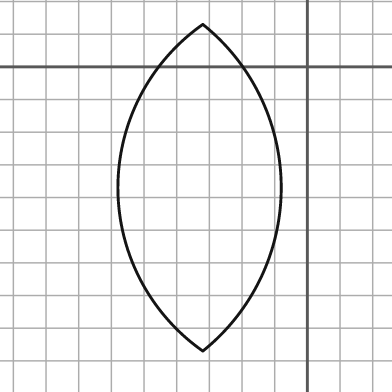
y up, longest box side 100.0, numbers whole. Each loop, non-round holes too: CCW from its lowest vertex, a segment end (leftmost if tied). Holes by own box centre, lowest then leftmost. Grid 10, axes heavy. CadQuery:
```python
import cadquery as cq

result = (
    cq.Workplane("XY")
    .moveTo(-32.0, -87.0)
    .threePointArc((-8.0, -37.0), (-32.0, 13.0))
    .threePointArc((-58.0, -37.0), (-32.0, -87.0))
    .close()
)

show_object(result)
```